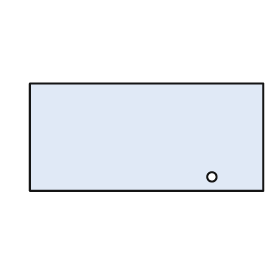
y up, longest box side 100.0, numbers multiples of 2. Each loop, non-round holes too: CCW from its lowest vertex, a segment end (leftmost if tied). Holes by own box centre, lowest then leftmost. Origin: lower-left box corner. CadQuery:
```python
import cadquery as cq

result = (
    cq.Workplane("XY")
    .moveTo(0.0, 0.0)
    .lineTo(100.0, 0.0)
    .lineTo(100.0, 46.0)
    .lineTo(0.0, 46.0)
    .close()
    .moveTo(78.0, 6.0)
    .circle(2.0)
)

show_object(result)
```